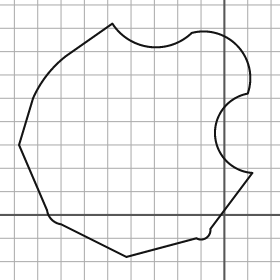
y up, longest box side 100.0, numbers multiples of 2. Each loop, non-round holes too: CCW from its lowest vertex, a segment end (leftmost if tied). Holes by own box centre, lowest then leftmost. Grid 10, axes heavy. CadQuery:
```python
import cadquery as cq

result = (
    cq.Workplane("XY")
    .moveTo(-42.0, -18.0)
    .lineTo(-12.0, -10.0)
    .threePointArc((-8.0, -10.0), (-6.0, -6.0))
    .lineTo(12.0, 18.0)
    .threePointArc((-4.0, 34.0), (10.0, 52.0))
    .threePointArc((6.0, 72.0), (-14.0, 78.0))
    .threePointArc((-32.0, 72.0), (-48.0, 82.0))
    .lineTo(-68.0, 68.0)
    .threePointArc((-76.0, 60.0), (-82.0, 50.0))
    .lineTo(-88.0, 30.0)
    .lineTo(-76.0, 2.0)
    .threePointArc((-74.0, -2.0), (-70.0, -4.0))
    .close()
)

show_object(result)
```